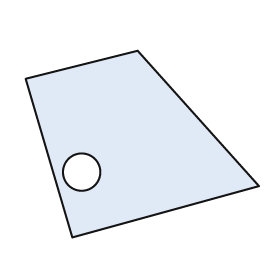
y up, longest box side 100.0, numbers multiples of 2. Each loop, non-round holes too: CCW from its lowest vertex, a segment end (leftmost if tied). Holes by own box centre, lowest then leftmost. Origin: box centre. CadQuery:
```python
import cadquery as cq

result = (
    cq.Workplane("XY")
    .moveTo(-30.0, -40.0)
    .lineTo(50.0, -18.0)
    .lineTo(-2.0, 40.0)
    .lineTo(-50.0, 28.0)
    .close()
    .moveTo(-26.0, -12.0)
    .circle(8.0)
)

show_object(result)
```